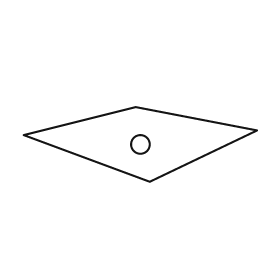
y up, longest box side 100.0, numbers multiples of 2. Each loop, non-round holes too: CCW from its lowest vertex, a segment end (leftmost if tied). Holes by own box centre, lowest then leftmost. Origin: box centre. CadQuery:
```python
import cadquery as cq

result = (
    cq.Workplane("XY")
    .moveTo(4.0, -16.0)
    .lineTo(50.0, 6.0)
    .lineTo(-2.0, 16.0)
    .lineTo(-50.0, 4.0)
    .close()
    .moveTo(0.0, 0.0)
    .circle(4.0)
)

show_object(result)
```